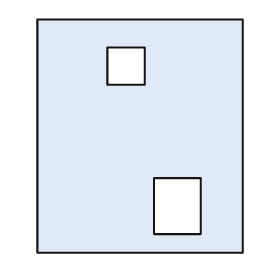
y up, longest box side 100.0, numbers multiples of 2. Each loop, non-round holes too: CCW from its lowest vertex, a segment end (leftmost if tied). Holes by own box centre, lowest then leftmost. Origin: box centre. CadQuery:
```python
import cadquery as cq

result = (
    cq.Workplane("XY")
    .moveTo(-44.0, -50.0)
    .lineTo(44.0, -50.0)
    .lineTo(44.0, 50.0)
    .lineTo(-44.0, 50.0)
    .close()
    .moveTo(6.0, -42.0)
    .lineTo(26.0, -42.0)
    .lineTo(26.0, -18.0)
    .lineTo(6.0, -18.0)
    .close()
    .moveTo(-14.0, 22.0)
    .lineTo(2.0, 22.0)
    .lineTo(2.0, 38.0)
    .lineTo(-14.0, 38.0)
    .close()
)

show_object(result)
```